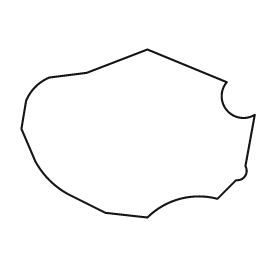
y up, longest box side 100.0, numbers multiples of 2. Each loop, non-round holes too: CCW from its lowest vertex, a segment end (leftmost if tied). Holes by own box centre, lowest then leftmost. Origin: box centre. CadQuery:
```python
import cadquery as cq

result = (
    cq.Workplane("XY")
    .moveTo(4.0, -36.0)
    .threePointArc((18.0, -28.0), (34.0, -28.0))
    .lineTo(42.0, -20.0)
    .threePointArc((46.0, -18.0), (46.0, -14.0))
    .lineTo(50.0, 8.0)
    .threePointArc((38.0, 10.0), (38.0, 22.0))
    .lineTo(4.0, 36.0)
    .lineTo(-22.0, 26.0)
    .lineTo(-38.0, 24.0)
    .threePointArc((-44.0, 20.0), (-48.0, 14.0))
    .lineTo(-50.0, 2.0)
    .lineTo(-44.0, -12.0)
    .threePointArc((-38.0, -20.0), (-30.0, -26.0))
    .lineTo(-14.0, -34.0)
    .close()
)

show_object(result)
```